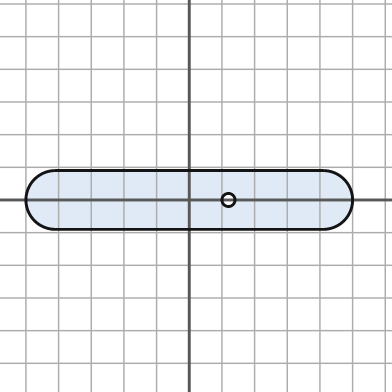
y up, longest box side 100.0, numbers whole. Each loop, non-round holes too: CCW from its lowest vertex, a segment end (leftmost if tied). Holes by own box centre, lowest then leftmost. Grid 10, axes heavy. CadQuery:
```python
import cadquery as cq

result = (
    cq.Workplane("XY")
    .moveTo(-41.0, -9.0)
    .lineTo(41.0, -9.0)
    .threePointArc((50.0, 0.0), (41.0, 9.0))
    .lineTo(-41.0, 9.0)
    .threePointArc((-50.0, 0.0), (-41.0, -9.0))
    .close()
    .moveTo(12.0, 0.0)
    .circle(2.0)
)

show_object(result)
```